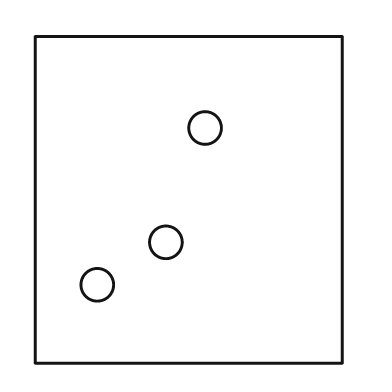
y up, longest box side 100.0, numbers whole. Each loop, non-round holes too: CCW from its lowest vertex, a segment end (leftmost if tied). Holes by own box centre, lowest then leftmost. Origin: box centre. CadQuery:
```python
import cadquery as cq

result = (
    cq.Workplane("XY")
    .moveTo(-47.0, -50.0)
    .lineTo(47.0, -50.0)
    .lineTo(47.0, 50.0)
    .lineTo(-47.0, 50.0)
    .close()
    .moveTo(-28.0, -26.0)
    .circle(5.0)
    .moveTo(-7.0, -13.0)
    .circle(5.0)
    .moveTo(5.0, 22.0)
    .circle(5.0)
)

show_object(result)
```